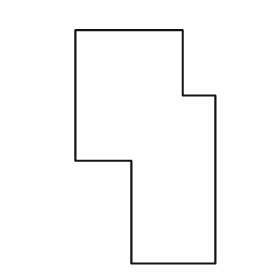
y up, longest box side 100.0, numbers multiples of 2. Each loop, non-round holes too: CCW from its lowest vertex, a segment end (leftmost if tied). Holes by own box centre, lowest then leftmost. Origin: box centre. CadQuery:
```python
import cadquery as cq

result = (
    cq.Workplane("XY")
    .moveTo(-6.0, -50.0)
    .lineTo(30.0, -50.0)
    .lineTo(30.0, 22.0)
    .lineTo(16.0, 22.0)
    .lineTo(16.0, 50.0)
    .lineTo(-30.0, 50.0)
    .lineTo(-30.0, -6.0)
    .lineTo(-6.0, -6.0)
    .close()
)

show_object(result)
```